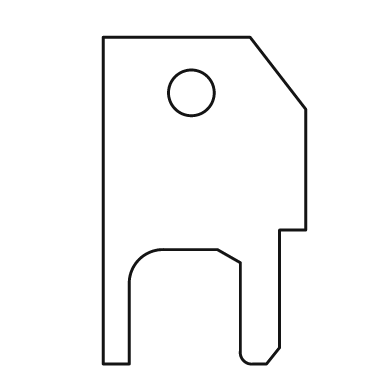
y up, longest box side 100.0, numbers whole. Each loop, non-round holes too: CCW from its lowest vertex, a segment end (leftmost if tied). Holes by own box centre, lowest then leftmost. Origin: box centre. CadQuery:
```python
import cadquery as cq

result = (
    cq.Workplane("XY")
    .moveTo(-31.0, -50.0)
    .lineTo(-23.0, -50.0)
    .lineTo(-23.0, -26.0)
    .threePointArc((-20.0, -18.0), (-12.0, -15.0))
    .lineTo(4.0, -15.0)
    .lineTo(11.0, -19.0)
    .lineTo(11.0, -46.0)
    .threePointArc((12.0, -49.0), (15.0, -50.0))
    .lineTo(19.0, -50.0)
    .lineTo(23.0, -45.0)
    .lineTo(23.0, -9.0)
    .lineTo(31.0, -9.0)
    .lineTo(31.0, 28.0)
    .lineTo(14.0, 50.0)
    .lineTo(-31.0, 50.0)
    .close()
    .moveTo(-4.0, 33.0)
    .circle(7.0)
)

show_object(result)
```